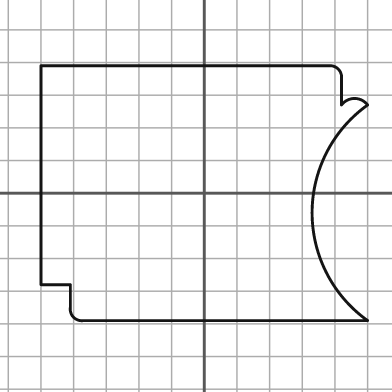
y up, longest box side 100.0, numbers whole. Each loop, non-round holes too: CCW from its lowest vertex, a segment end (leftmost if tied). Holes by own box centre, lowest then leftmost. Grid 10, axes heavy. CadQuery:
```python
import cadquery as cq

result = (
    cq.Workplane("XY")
    .moveTo(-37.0, -39.0)
    .lineTo(50.0, -39.0)
    .threePointArc((33.0, -6.0), (50.0, 27.0))
    .threePointArc((46.0, 29.0), (42.0, 27.0))
    .lineTo(42.0, 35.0)
    .threePointArc((41.0, 38.0), (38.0, 39.0))
    .lineTo(-50.0, 39.0)
    .lineTo(-50.0, -28.0)
    .lineTo(-41.0, -28.0)
    .lineTo(-41.0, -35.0)
    .threePointArc((-40.0, -38.0), (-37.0, -39.0))
    .close()
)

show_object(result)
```